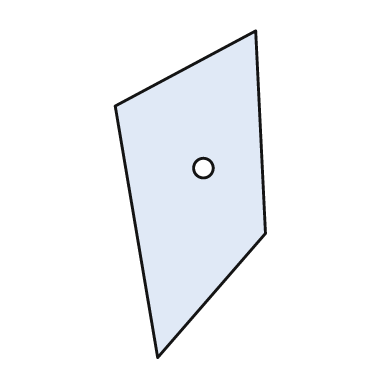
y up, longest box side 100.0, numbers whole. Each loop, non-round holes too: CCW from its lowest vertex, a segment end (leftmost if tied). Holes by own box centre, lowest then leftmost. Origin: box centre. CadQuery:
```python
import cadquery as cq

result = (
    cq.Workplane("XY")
    .moveTo(-10.0, -50.0)
    .lineTo(23.0, -12.0)
    .lineTo(20.0, 50.0)
    .lineTo(-23.0, 27.0)
    .close()
    .moveTo(4.0, 8.0)
    .circle(3.0)
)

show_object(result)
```